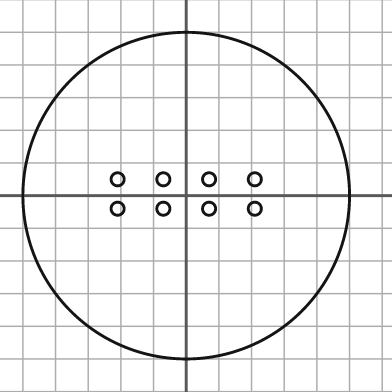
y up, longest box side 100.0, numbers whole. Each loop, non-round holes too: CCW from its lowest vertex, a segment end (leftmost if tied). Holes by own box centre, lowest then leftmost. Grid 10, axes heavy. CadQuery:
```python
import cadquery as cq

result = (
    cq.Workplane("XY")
    .moveTo(0.0, 0.0)
    .circle(50.0)
    .moveTo(-21.0, -4.0)
    .circle(2.0)
    .moveTo(-7.0, -4.0)
    .circle(2.0)
    .moveTo(7.0, -4.0)
    .circle(2.0)
    .moveTo(21.0, -4.0)
    .circle(2.0)
    .moveTo(-21.0, 5.0)
    .circle(2.0)
    .moveTo(-7.0, 5.0)
    .circle(2.0)
    .moveTo(7.0, 5.0)
    .circle(2.0)
    .moveTo(21.0, 5.0)
    .circle(2.0)
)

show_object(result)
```